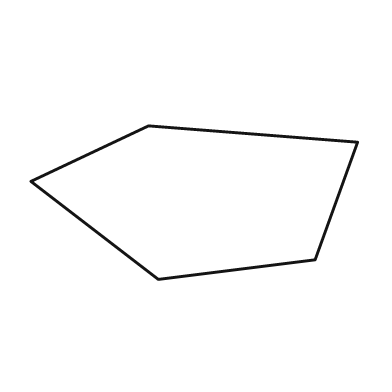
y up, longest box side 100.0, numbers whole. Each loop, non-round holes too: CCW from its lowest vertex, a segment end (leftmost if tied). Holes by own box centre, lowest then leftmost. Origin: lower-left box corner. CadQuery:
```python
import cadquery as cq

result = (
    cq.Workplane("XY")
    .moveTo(39.0, 0.0)
    .lineTo(87.0, 6.0)
    .lineTo(100.0, 42.0)
    .lineTo(36.0, 47.0)
    .lineTo(0.0, 30.0)
    .close()
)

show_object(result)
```